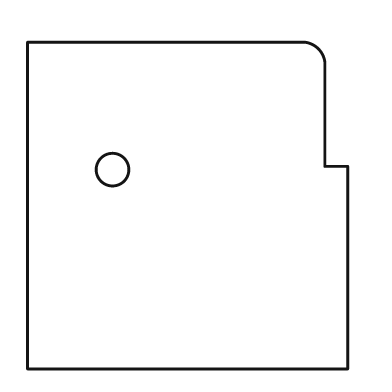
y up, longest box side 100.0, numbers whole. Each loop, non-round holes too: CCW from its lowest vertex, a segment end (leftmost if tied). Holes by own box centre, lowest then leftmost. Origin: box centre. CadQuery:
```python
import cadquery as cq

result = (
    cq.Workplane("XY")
    .moveTo(-49.0, -50.0)
    .lineTo(49.0, -50.0)
    .lineTo(49.0, 12.0)
    .lineTo(42.0, 12.0)
    .lineTo(42.0, 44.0)
    .threePointArc((40.0, 48.0), (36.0, 50.0))
    .lineTo(-49.0, 50.0)
    .close()
    .moveTo(-23.0, 11.0)
    .circle(5.0)
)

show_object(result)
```